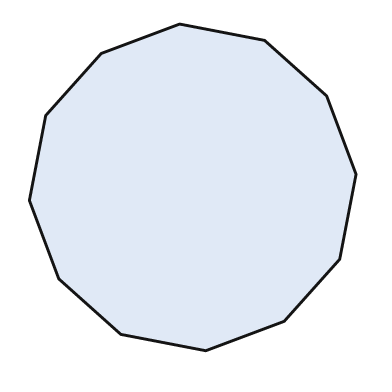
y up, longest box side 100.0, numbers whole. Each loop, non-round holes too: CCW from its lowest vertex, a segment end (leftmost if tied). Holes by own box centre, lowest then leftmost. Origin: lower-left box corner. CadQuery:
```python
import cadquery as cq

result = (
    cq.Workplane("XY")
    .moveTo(54.0, 0.0)
    .lineTo(78.0, 9.0)
    .lineTo(95.0, 28.0)
    .lineTo(100.0, 54.0)
    .lineTo(91.0, 78.0)
    .lineTo(72.0, 95.0)
    .lineTo(46.0, 100.0)
    .lineTo(22.0, 91.0)
    .lineTo(5.0, 72.0)
    .lineTo(0.0, 46.0)
    .lineTo(9.0, 22.0)
    .lineTo(28.0, 5.0)
    .close()
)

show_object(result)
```